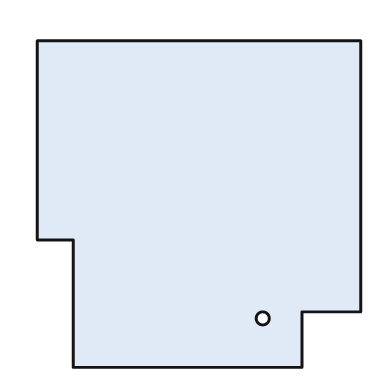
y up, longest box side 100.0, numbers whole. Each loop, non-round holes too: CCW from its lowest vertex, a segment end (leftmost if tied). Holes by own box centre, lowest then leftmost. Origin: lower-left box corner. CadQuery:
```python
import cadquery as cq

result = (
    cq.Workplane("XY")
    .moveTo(11.0, 0.0)
    .lineTo(81.0, 0.0)
    .lineTo(81.0, 17.0)
    .lineTo(99.0, 17.0)
    .lineTo(99.0, 100.0)
    .lineTo(0.0, 100.0)
    .lineTo(0.0, 39.0)
    .lineTo(11.0, 39.0)
    .close()
    .moveTo(69.0, 15.0)
    .circle(2.0)
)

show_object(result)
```